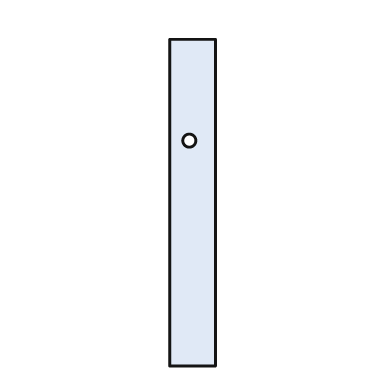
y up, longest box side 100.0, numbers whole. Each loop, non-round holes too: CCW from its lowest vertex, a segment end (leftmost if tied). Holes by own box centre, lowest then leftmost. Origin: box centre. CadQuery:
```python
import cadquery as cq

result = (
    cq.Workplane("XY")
    .moveTo(-7.0, -50.0)
    .lineTo(7.0, -50.0)
    .lineTo(7.0, 50.0)
    .lineTo(-7.0, 50.0)
    .close()
    .moveTo(-1.0, 19.0)
    .circle(2.0)
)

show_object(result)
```